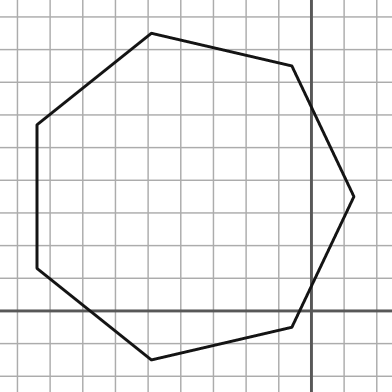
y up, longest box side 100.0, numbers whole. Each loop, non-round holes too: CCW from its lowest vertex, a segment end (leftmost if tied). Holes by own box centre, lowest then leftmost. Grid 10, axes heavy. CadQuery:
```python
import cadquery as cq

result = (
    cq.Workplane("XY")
    .moveTo(-49.0, -15.0)
    .lineTo(-6.0, -5.0)
    .lineTo(13.0, 35.0)
    .lineTo(-6.0, 75.0)
    .lineTo(-49.0, 85.0)
    .lineTo(-84.0, 57.0)
    .lineTo(-84.0, 13.0)
    .close()
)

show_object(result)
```